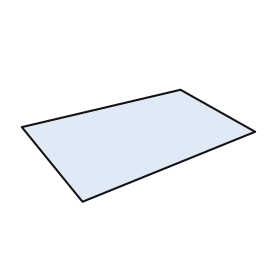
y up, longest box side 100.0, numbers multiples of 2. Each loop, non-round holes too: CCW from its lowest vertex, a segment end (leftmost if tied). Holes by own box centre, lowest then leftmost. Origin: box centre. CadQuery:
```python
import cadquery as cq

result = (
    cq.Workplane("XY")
    .moveTo(-24.0, -24.0)
    .lineTo(50.0, 6.0)
    .lineTo(18.0, 24.0)
    .lineTo(-50.0, 8.0)
    .close()
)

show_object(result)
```